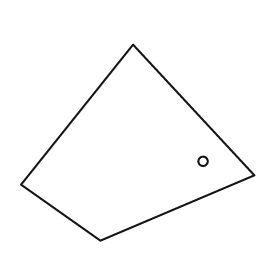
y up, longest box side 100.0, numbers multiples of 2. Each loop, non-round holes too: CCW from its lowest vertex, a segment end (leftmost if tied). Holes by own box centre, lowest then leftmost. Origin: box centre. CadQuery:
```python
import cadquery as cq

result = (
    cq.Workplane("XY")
    .moveTo(-16.0, -42.0)
    .lineTo(50.0, -14.0)
    .lineTo(-2.0, 42.0)
    .lineTo(-50.0, -18.0)
    .close()
    .moveTo(28.0, -8.0)
    .circle(2.0)
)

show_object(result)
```